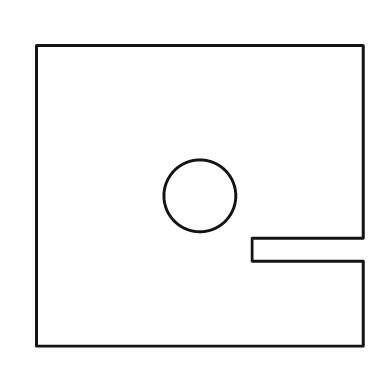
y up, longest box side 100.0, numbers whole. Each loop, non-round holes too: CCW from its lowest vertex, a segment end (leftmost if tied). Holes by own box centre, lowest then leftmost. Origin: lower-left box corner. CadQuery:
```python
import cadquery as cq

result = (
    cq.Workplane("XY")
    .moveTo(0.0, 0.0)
    .lineTo(100.0, 0.0)
    .lineTo(100.0, 26.0)
    .lineTo(66.0, 26.0)
    .lineTo(66.0, 33.0)
    .lineTo(100.0, 33.0)
    .lineTo(100.0, 92.0)
    .lineTo(0.0, 92.0)
    .close()
    .moveTo(50.0, 46.0)
    .circle(11.0)
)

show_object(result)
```